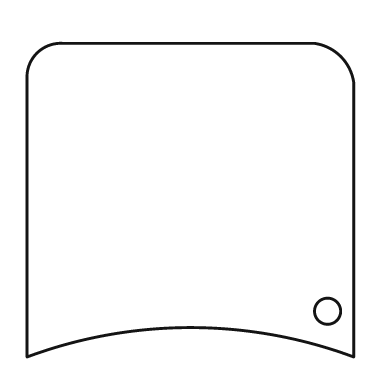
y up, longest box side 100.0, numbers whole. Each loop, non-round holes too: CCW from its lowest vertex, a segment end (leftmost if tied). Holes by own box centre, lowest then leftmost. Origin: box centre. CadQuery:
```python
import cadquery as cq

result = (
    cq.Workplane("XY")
    .moveTo(-50.0, -48.0)
    .threePointArc((0.0, -39.0), (50.0, -48.0))
    .lineTo(50.0, 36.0)
    .threePointArc((46.0, 44.0), (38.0, 48.0))
    .lineTo(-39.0, 48.0)
    .threePointArc((-47.0, 45.0), (-50.0, 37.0))
    .close()
    .moveTo(42.0, -34.0)
    .circle(4.0)
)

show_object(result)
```